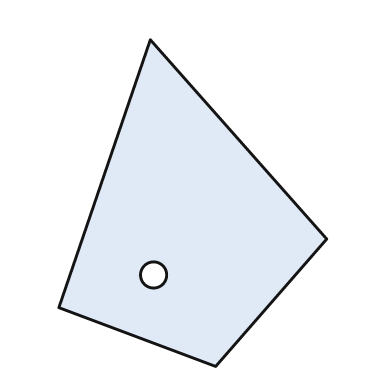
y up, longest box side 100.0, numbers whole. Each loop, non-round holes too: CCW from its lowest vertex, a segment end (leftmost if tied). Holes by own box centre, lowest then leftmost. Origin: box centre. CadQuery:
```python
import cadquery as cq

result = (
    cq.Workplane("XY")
    .moveTo(7.0, -50.0)
    .lineTo(41.0, -11.0)
    .lineTo(-13.0, 50.0)
    .lineTo(-41.0, -32.0)
    .close()
    .moveTo(-12.0, -22.0)
    .circle(4.0)
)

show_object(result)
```